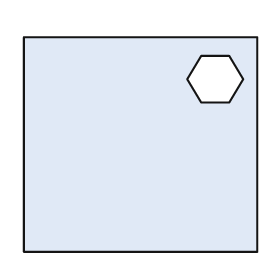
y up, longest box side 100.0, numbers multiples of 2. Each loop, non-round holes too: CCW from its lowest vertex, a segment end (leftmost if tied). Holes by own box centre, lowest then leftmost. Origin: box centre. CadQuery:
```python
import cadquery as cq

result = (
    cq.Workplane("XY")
    .moveTo(-50.0, -46.0)
    .lineTo(50.0, -46.0)
    .lineTo(50.0, 46.0)
    .lineTo(-50.0, 46.0)
    .close()
    .moveTo(26.0, 18.0)
    .lineTo(38.0, 18.0)
    .lineTo(44.0, 28.0)
    .lineTo(38.0, 38.0)
    .lineTo(26.0, 38.0)
    .lineTo(20.0, 28.0)
    .close()
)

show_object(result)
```